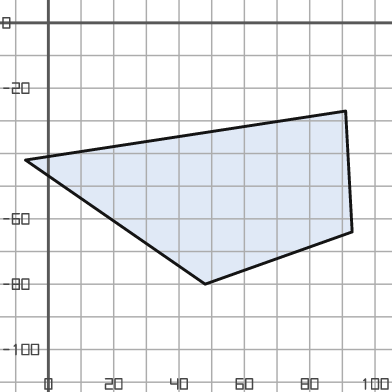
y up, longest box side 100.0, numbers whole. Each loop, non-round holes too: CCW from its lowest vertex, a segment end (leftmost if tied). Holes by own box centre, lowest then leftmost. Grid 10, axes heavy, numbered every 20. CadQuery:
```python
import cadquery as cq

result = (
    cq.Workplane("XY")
    .moveTo(48.0, -80.0)
    .lineTo(93.0, -64.0)
    .lineTo(91.0, -27.0)
    .lineTo(-7.0, -42.0)
    .close()
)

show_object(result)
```